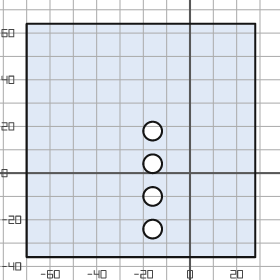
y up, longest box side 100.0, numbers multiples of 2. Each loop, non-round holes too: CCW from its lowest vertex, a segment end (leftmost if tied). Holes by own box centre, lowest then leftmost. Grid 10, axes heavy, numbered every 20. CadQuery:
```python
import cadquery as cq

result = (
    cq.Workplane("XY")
    .moveTo(-70.0, -36.0)
    .lineTo(28.0, -36.0)
    .lineTo(28.0, 64.0)
    .lineTo(-70.0, 64.0)
    .close()
    .moveTo(-16.0, -24.0)
    .circle(4.0)
    .moveTo(-16.0, -10.0)
    .circle(4.0)
    .moveTo(-16.0, 4.0)
    .circle(4.0)
    .moveTo(-16.0, 18.0)
    .circle(4.0)
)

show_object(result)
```